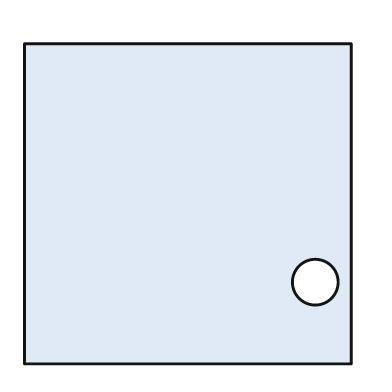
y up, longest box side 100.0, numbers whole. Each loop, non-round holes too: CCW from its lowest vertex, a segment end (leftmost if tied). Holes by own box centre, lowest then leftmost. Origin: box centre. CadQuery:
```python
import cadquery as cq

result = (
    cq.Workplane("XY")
    .moveTo(-50.0, -49.0)
    .lineTo(50.0, -49.0)
    .lineTo(50.0, 49.0)
    .lineTo(-50.0, 49.0)
    .close()
    .moveTo(39.0, -24.0)
    .circle(7.0)
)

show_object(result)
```